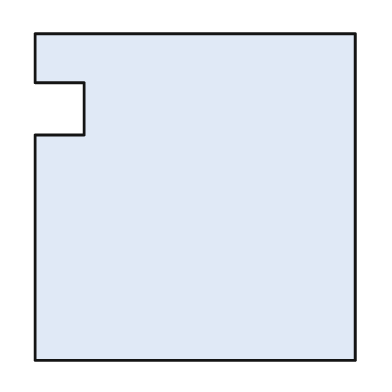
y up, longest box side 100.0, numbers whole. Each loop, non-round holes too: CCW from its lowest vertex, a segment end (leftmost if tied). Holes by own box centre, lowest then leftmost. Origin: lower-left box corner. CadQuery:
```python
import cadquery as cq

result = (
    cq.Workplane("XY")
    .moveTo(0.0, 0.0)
    .lineTo(98.0, 0.0)
    .lineTo(98.0, 100.0)
    .lineTo(0.0, 100.0)
    .lineTo(0.0, 85.0)
    .lineTo(15.0, 85.0)
    .lineTo(15.0, 69.0)
    .lineTo(0.0, 69.0)
    .close()
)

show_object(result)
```